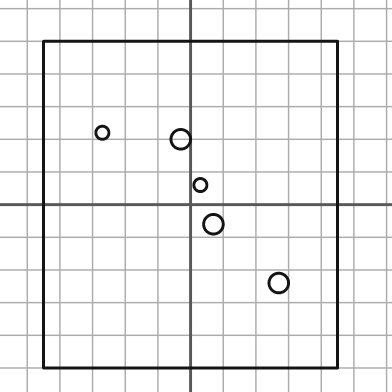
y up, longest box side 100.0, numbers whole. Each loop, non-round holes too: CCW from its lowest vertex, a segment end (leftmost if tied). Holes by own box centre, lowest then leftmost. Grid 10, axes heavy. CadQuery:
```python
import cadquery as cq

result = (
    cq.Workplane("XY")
    .moveTo(-45.0, -50.0)
    .lineTo(45.0, -50.0)
    .lineTo(45.0, 50.0)
    .lineTo(-45.0, 50.0)
    .close()
    .moveTo(27.0, -24.0)
    .circle(3.0)
    .moveTo(7.0, -6.0)
    .circle(3.0)
    .moveTo(3.0, 6.0)
    .circle(2.0)
    .moveTo(-3.0, 20.0)
    .circle(3.0)
    .moveTo(-27.0, 22.0)
    .circle(2.0)
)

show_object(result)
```